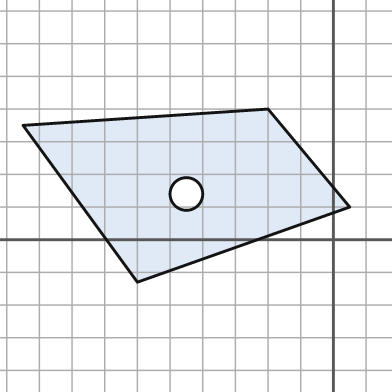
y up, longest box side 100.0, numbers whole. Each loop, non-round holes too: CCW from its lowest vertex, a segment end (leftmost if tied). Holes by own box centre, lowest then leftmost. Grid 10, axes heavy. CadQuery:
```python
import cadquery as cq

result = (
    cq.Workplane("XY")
    .moveTo(-60.0, -13.0)
    .lineTo(5.0, 10.0)
    .lineTo(-20.0, 40.0)
    .lineTo(-95.0, 35.0)
    .close()
    .moveTo(-45.0, 14.0)
    .circle(5.0)
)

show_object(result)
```